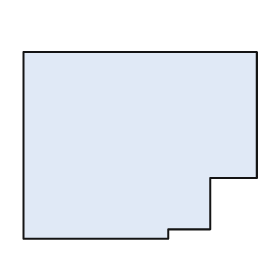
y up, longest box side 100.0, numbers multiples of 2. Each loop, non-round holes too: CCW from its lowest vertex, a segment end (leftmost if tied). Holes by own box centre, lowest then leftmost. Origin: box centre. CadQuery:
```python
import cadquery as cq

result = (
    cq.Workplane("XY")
    .moveTo(-50.0, -40.0)
    .lineTo(12.0, -40.0)
    .lineTo(12.0, -36.0)
    .lineTo(30.0, -36.0)
    .lineTo(30.0, -14.0)
    .lineTo(50.0, -14.0)
    .lineTo(50.0, 40.0)
    .lineTo(-50.0, 40.0)
    .close()
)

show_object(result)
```